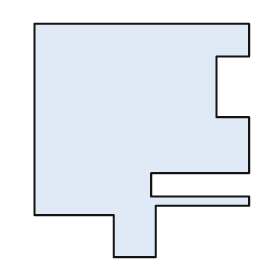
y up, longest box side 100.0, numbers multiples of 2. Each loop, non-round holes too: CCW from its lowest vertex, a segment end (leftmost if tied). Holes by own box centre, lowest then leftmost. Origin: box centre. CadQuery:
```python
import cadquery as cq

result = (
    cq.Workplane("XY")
    .moveTo(-12.0, -50.0)
    .lineTo(6.0, -50.0)
    .lineTo(6.0, -28.0)
    .lineTo(46.0, -28.0)
    .lineTo(46.0, -24.0)
    .lineTo(4.0, -24.0)
    .lineTo(4.0, -14.0)
    .lineTo(46.0, -14.0)
    .lineTo(46.0, 10.0)
    .lineTo(32.0, 10.0)
    .lineTo(32.0, 36.0)
    .lineTo(46.0, 36.0)
    .lineTo(46.0, 50.0)
    .lineTo(-46.0, 50.0)
    .lineTo(-46.0, -32.0)
    .lineTo(-12.0, -32.0)
    .close()
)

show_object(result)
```